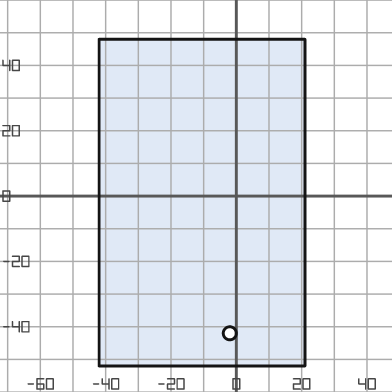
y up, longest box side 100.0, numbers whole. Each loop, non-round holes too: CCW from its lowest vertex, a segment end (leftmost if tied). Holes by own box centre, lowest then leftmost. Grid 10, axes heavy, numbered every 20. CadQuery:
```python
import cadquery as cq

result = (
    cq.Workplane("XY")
    .moveTo(-42.0, -52.0)
    .lineTo(21.0, -52.0)
    .lineTo(21.0, 48.0)
    .lineTo(-42.0, 48.0)
    .close()
    .moveTo(-2.0, -42.0)
    .circle(2.0)
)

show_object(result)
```